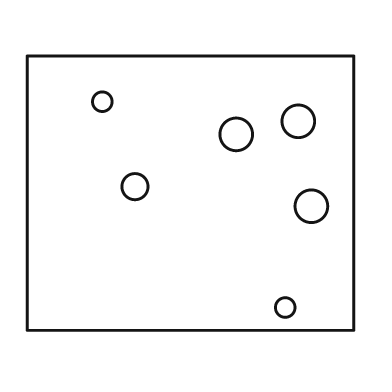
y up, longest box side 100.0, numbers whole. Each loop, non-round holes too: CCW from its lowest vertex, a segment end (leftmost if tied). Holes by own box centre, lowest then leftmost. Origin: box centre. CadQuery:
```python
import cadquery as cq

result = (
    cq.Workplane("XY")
    .moveTo(-50.0, -42.0)
    .lineTo(50.0, -42.0)
    .lineTo(50.0, 42.0)
    .lineTo(-50.0, 42.0)
    .close()
    .moveTo(29.0, -35.0)
    .circle(3.0)
    .moveTo(37.0, -4.0)
    .circle(5.0)
    .moveTo(-17.0, 2.0)
    .circle(4.0)
    .moveTo(14.0, 18.0)
    .circle(5.0)
    .moveTo(33.0, 22.0)
    .circle(5.0)
    .moveTo(-27.0, 28.0)
    .circle(3.0)
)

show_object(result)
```